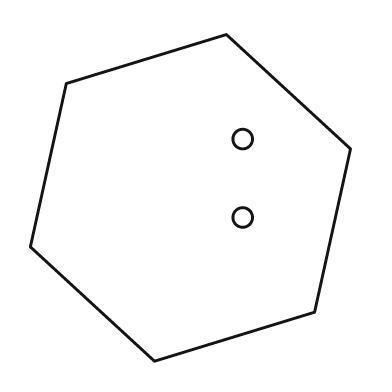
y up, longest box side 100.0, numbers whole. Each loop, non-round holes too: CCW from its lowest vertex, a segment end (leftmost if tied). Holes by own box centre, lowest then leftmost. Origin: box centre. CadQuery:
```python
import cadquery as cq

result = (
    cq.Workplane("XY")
    .moveTo(-11.0, -50.0)
    .lineTo(38.0, -35.0)
    .lineTo(49.0, 15.0)
    .lineTo(11.0, 50.0)
    .lineTo(-38.0, 35.0)
    .lineTo(-49.0, -15.0)
    .close()
    .moveTo(16.0, -6.0)
    .circle(3.0)
    .moveTo(16.0, 18.0)
    .circle(3.0)
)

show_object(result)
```